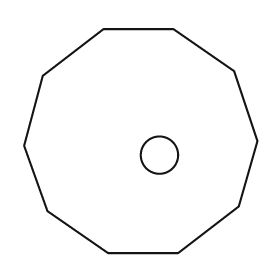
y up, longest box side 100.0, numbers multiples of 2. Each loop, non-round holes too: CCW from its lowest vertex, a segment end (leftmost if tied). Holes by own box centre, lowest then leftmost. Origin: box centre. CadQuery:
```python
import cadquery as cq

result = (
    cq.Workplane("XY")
    .moveTo(-14.0, -48.0)
    .lineTo(16.0, -48.0)
    .lineTo(42.0, -28.0)
    .lineTo(50.0, 0.0)
    .lineTo(40.0, 30.0)
    .lineTo(14.0, 48.0)
    .lineTo(-16.0, 48.0)
    .lineTo(-42.0, 28.0)
    .lineTo(-50.0, -2.0)
    .lineTo(-40.0, -30.0)
    .close()
    .moveTo(8.0, -6.0)
    .circle(8.0)
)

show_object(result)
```